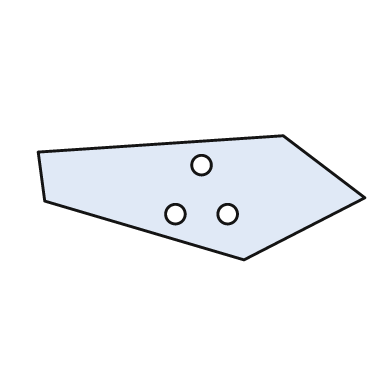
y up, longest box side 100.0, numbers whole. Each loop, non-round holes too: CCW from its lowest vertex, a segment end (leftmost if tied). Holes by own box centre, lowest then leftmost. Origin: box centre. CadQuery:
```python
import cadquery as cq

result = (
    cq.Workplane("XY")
    .moveTo(13.0, -19.0)
    .lineTo(50.0, 0.0)
    .lineTo(25.0, 19.0)
    .lineTo(-50.0, 14.0)
    .lineTo(-48.0, -1.0)
    .close()
    .moveTo(-8.0, -5.0)
    .circle(3.0)
    .moveTo(8.0, -5.0)
    .circle(3.0)
    .moveTo(0.0, 10.0)
    .circle(3.0)
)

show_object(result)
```